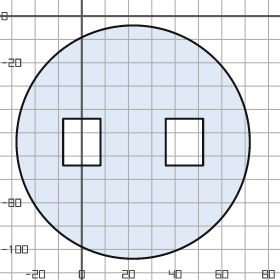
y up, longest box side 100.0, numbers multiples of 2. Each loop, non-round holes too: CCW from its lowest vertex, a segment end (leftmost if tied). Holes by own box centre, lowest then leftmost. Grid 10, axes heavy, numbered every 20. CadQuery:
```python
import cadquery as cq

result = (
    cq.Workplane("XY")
    .moveTo(22.0, -54.0)
    .circle(50.0)
    .moveTo(-8.0, -64.0)
    .lineTo(8.0, -64.0)
    .lineTo(8.0, -44.0)
    .lineTo(-8.0, -44.0)
    .close()
    .moveTo(36.0, -64.0)
    .lineTo(52.0, -64.0)
    .lineTo(52.0, -44.0)
    .lineTo(36.0, -44.0)
    .close()
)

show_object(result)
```